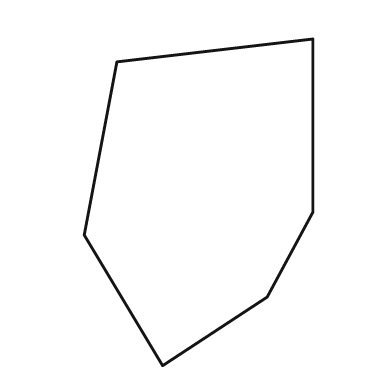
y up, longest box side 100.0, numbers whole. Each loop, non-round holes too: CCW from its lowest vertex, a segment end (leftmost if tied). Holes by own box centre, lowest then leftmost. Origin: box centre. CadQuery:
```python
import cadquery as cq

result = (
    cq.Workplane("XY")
    .moveTo(-11.0, -50.0)
    .lineTo(21.0, -29.0)
    .lineTo(35.0, -3.0)
    .lineTo(35.0, 50.0)
    .lineTo(-25.0, 43.0)
    .lineTo(-35.0, -10.0)
    .close()
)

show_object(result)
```